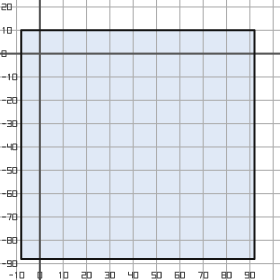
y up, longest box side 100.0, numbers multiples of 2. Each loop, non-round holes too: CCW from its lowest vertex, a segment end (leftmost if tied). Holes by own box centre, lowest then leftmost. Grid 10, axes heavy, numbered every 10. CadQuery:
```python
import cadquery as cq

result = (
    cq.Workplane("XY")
    .moveTo(-8.0, -88.0)
    .lineTo(92.0, -88.0)
    .lineTo(92.0, 10.0)
    .lineTo(-8.0, 10.0)
    .close()
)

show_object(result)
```